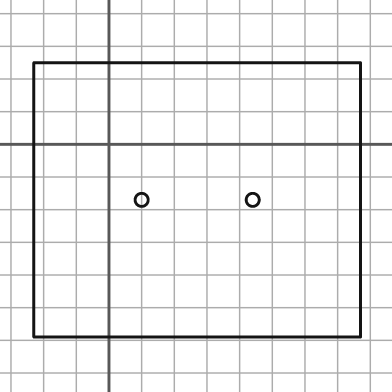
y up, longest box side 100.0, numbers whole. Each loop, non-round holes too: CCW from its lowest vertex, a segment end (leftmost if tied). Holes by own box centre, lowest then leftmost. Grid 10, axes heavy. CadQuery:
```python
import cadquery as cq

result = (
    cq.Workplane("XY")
    .moveTo(-23.0, -59.0)
    .lineTo(77.0, -59.0)
    .lineTo(77.0, 25.0)
    .lineTo(-23.0, 25.0)
    .close()
    .moveTo(10.0, -17.0)
    .circle(2.0)
    .moveTo(44.0, -17.0)
    .circle(2.0)
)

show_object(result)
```